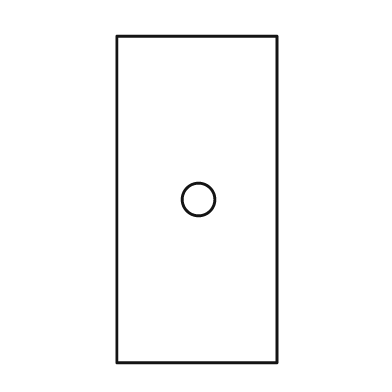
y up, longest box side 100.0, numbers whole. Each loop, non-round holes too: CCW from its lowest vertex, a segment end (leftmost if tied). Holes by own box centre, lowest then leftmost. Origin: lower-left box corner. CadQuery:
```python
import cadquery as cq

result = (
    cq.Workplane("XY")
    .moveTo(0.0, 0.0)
    .lineTo(49.0, 0.0)
    .lineTo(49.0, 100.0)
    .lineTo(0.0, 100.0)
    .close()
    .moveTo(25.0, 50.0)
    .circle(5.0)
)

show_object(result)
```